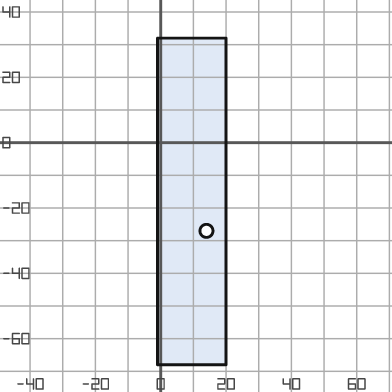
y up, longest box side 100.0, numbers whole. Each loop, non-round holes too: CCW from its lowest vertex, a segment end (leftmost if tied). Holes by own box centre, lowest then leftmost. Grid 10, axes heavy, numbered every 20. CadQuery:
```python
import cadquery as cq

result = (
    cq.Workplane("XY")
    .moveTo(-1.0, -68.0)
    .lineTo(20.0, -68.0)
    .lineTo(20.0, 32.0)
    .lineTo(-1.0, 32.0)
    .close()
    .moveTo(14.0, -27.0)
    .circle(2.0)
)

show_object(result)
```